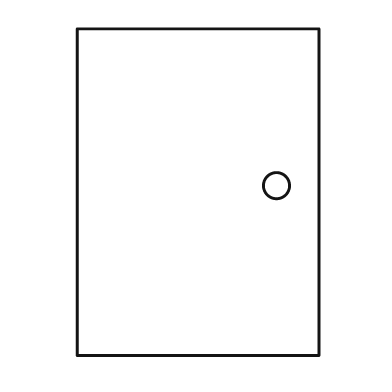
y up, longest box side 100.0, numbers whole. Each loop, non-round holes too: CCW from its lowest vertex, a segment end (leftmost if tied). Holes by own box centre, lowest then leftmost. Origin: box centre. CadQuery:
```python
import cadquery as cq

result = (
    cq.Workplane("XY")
    .moveTo(-37.0, -50.0)
    .lineTo(37.0, -50.0)
    .lineTo(37.0, 50.0)
    .lineTo(-37.0, 50.0)
    .close()
    .moveTo(24.0, 2.0)
    .circle(4.0)
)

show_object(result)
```